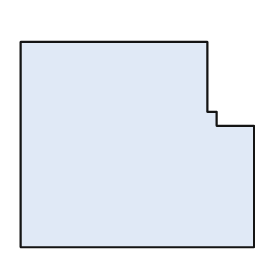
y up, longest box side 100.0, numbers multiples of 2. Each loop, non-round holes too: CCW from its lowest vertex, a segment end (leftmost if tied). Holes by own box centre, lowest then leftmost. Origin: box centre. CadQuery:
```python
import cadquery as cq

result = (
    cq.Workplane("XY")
    .moveTo(-50.0, -44.0)
    .lineTo(50.0, -44.0)
    .lineTo(50.0, 8.0)
    .lineTo(34.0, 8.0)
    .lineTo(34.0, 14.0)
    .lineTo(30.0, 14.0)
    .lineTo(30.0, 44.0)
    .lineTo(-50.0, 44.0)
    .close()
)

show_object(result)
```